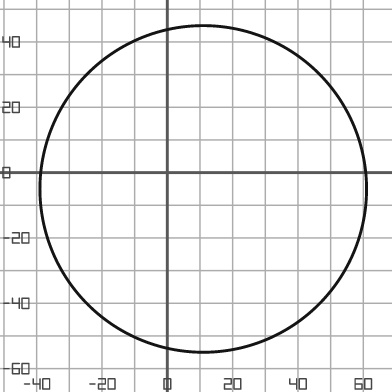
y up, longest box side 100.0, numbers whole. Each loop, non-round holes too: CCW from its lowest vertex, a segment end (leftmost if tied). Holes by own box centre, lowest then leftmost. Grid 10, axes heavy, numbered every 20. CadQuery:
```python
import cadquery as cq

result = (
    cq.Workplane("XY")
    .moveTo(11.0, -5.0)
    .circle(50.0)
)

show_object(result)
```